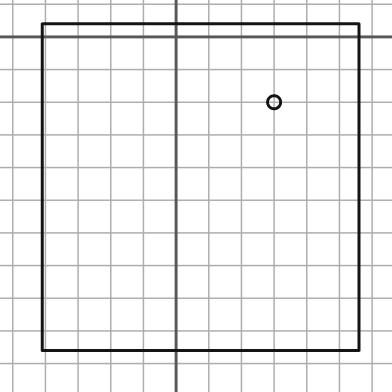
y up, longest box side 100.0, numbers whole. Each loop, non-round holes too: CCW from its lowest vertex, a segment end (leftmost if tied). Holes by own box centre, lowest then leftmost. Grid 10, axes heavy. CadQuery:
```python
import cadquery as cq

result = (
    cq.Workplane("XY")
    .moveTo(-41.0, -96.0)
    .lineTo(56.0, -96.0)
    .lineTo(56.0, 4.0)
    .lineTo(-41.0, 4.0)
    .close()
    .moveTo(30.0, -20.0)
    .circle(2.0)
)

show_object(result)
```